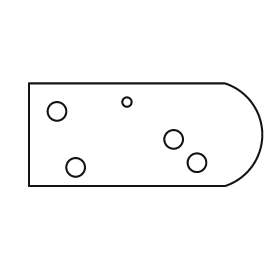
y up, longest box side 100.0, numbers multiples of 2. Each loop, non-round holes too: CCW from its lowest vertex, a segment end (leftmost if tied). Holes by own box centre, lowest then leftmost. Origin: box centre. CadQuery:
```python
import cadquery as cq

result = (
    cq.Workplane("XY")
    .moveTo(-50.0, -22.0)
    .lineTo(34.0, -22.0)
    .threePointArc((50.0, 0.0), (34.0, 22.0))
    .lineTo(-50.0, 22.0)
    .close()
    .moveTo(-30.0, -14.0)
    .circle(4.0)
    .moveTo(22.0, -12.0)
    .circle(4.0)
    .moveTo(12.0, -2.0)
    .circle(4.0)
    .moveTo(-38.0, 10.0)
    .circle(4.0)
    .moveTo(-8.0, 14.0)
    .circle(2.0)
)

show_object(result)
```